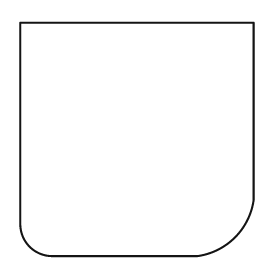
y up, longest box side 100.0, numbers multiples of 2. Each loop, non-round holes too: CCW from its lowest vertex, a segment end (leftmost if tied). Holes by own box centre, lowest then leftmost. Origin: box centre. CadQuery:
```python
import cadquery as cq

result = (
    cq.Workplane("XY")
    .moveTo(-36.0, -50.0)
    .lineTo(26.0, -50.0)
    .threePointArc((42.0, -42.0), (50.0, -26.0))
    .lineTo(50.0, 50.0)
    .lineTo(-50.0, 50.0)
    .lineTo(-50.0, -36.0)
    .threePointArc((-46.0, -46.0), (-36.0, -50.0))
    .close()
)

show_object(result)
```